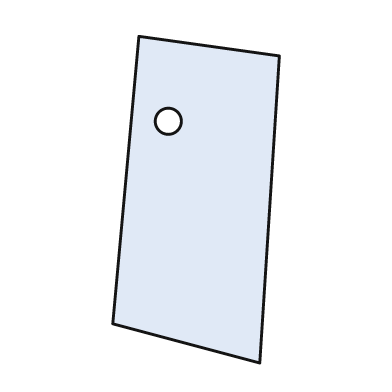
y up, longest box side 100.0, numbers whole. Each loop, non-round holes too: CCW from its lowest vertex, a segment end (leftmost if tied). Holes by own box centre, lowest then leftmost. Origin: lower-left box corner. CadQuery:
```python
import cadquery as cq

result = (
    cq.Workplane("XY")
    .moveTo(45.0, 0.0)
    .lineTo(51.0, 94.0)
    .lineTo(8.0, 100.0)
    .lineTo(0.0, 12.0)
    .close()
    .moveTo(17.0, 74.0)
    .circle(4.0)
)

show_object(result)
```